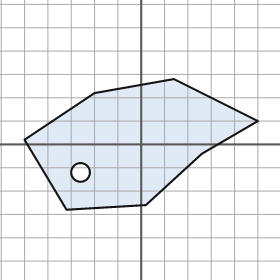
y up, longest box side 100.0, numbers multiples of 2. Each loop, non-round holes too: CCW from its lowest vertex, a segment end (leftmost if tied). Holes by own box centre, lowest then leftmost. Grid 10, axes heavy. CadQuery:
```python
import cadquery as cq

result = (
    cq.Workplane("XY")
    .moveTo(-32.0, -28.0)
    .lineTo(2.0, -26.0)
    .lineTo(26.0, -4.0)
    .lineTo(50.0, 10.0)
    .lineTo(14.0, 28.0)
    .lineTo(-20.0, 22.0)
    .lineTo(-50.0, 2.0)
    .close()
    .moveTo(-26.0, -12.0)
    .circle(4.0)
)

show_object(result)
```